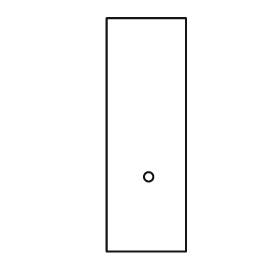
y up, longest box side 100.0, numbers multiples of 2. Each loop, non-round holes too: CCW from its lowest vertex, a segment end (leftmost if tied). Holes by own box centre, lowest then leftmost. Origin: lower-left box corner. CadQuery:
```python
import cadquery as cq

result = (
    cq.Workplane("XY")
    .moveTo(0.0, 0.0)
    .lineTo(34.0, 0.0)
    .lineTo(34.0, 100.0)
    .lineTo(0.0, 100.0)
    .close()
    .moveTo(18.0, 32.0)
    .circle(2.0)
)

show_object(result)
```